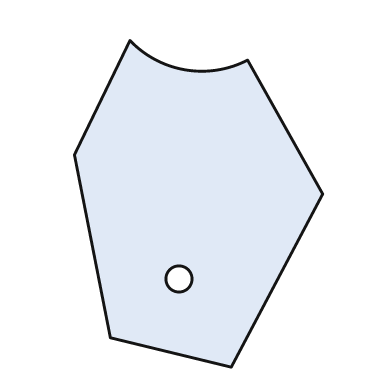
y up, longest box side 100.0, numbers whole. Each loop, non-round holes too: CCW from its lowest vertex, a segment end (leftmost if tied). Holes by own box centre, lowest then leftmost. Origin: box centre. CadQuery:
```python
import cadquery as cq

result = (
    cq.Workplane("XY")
    .moveTo(10.0, -50.0)
    .lineTo(38.0, 3.0)
    .lineTo(15.0, 44.0)
    .threePointArc((-4.0, 41.0), (-21.0, 50.0))
    .lineTo(-38.0, 15.0)
    .lineTo(-27.0, -41.0)
    .close()
    .moveTo(-6.0, -23.0)
    .circle(4.0)
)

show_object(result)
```